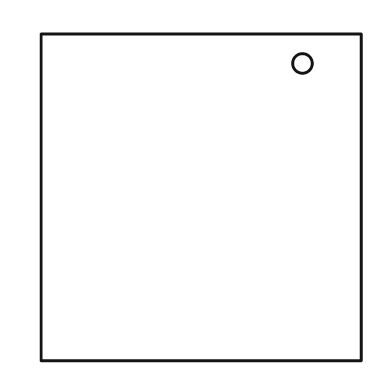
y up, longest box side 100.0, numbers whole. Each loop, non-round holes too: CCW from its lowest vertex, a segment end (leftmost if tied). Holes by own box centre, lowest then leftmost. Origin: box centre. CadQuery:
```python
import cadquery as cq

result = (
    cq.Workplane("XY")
    .moveTo(-49.0, -50.0)
    .lineTo(49.0, -50.0)
    .lineTo(49.0, 50.0)
    .lineTo(-49.0, 50.0)
    .close()
    .moveTo(31.0, 41.0)
    .circle(3.0)
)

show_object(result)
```